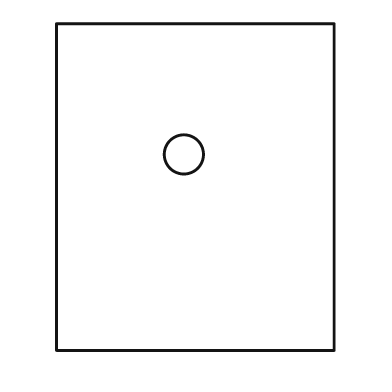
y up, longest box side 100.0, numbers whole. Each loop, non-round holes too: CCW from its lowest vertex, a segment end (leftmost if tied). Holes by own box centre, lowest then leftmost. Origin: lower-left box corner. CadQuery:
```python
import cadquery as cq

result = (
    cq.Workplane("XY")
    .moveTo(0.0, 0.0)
    .lineTo(85.0, 0.0)
    .lineTo(85.0, 100.0)
    .lineTo(0.0, 100.0)
    .close()
    .moveTo(39.0, 60.0)
    .circle(6.0)
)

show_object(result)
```